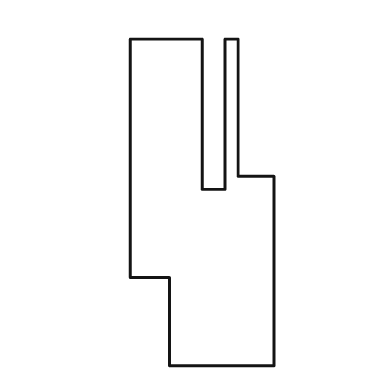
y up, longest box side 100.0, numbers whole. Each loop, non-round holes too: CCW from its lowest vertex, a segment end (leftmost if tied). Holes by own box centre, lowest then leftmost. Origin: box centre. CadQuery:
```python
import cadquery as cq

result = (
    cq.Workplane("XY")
    .moveTo(-10.0, -50.0)
    .lineTo(22.0, -50.0)
    .lineTo(22.0, 8.0)
    .lineTo(11.0, 8.0)
    .lineTo(11.0, 50.0)
    .lineTo(7.0, 50.0)
    .lineTo(7.0, 4.0)
    .lineTo(0.0, 4.0)
    .lineTo(0.0, 50.0)
    .lineTo(-22.0, 50.0)
    .lineTo(-22.0, -23.0)
    .lineTo(-10.0, -23.0)
    .close()
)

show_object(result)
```